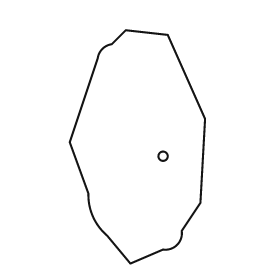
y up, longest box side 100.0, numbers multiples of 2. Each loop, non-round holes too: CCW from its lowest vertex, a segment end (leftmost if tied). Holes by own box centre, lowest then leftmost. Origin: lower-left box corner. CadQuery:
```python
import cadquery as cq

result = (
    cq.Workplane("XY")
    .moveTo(26.0, 0.0)
    .lineTo(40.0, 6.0)
    .threePointArc((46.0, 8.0), (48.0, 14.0))
    .lineTo(56.0, 26.0)
    .lineTo(58.0, 62.0)
    .lineTo(42.0, 98.0)
    .lineTo(24.0, 100.0)
    .lineTo(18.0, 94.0)
    .threePointArc((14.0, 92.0), (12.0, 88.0))
    .lineTo(0.0, 52.0)
    .lineTo(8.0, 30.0)
    .threePointArc((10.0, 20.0), (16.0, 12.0))
    .close()
    .moveTo(40.0, 46.0)
    .circle(2.0)
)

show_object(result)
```